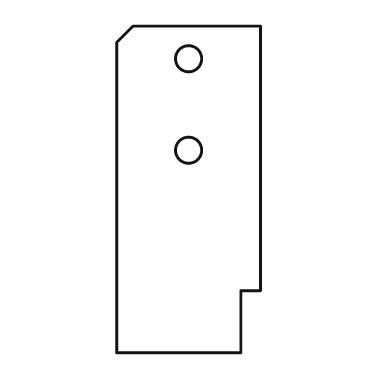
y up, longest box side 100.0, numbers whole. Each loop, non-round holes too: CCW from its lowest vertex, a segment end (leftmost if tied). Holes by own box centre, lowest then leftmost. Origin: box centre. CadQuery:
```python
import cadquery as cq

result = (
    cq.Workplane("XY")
    .moveTo(-22.0, -50.0)
    .lineTo(16.0, -50.0)
    .lineTo(16.0, -31.0)
    .lineTo(22.0, -31.0)
    .lineTo(22.0, 50.0)
    .lineTo(-17.0, 50.0)
    .lineTo(-22.0, 45.0)
    .close()
    .moveTo(0.0, 12.0)
    .circle(4.0)
    .moveTo(0.0, 40.0)
    .circle(4.0)
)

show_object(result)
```